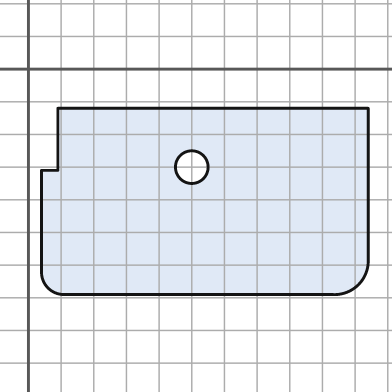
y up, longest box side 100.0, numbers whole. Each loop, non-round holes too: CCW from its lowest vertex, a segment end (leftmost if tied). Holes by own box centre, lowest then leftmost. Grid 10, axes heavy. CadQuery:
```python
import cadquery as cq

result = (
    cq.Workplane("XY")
    .moveTo(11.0, -69.0)
    .lineTo(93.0, -69.0)
    .threePointArc((101.0, -66.0), (104.0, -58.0))
    .lineTo(104.0, -12.0)
    .lineTo(9.0, -12.0)
    .lineTo(9.0, -31.0)
    .lineTo(4.0, -31.0)
    .lineTo(4.0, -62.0)
    .threePointArc((6.0, -67.0), (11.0, -69.0))
    .close()
    .moveTo(50.0, -30.0)
    .circle(5.0)
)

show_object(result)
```